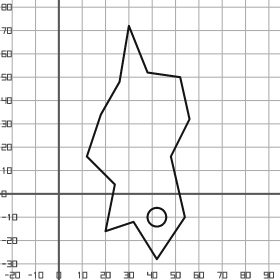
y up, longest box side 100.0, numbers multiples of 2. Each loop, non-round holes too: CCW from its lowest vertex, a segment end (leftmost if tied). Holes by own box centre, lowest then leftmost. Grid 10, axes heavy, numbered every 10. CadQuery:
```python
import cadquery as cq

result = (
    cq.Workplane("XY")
    .moveTo(42.0, -28.0)
    .lineTo(54.0, -10.0)
    .lineTo(48.0, 16.0)
    .lineTo(56.0, 32.0)
    .lineTo(52.0, 50.0)
    .lineTo(38.0, 52.0)
    .lineTo(30.0, 72.0)
    .lineTo(26.0, 48.0)
    .lineTo(18.0, 34.0)
    .lineTo(12.0, 16.0)
    .lineTo(24.0, 4.0)
    .lineTo(20.0, -16.0)
    .lineTo(32.0, -12.0)
    .close()
    .moveTo(42.0, -10.0)
    .circle(4.0)
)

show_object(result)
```